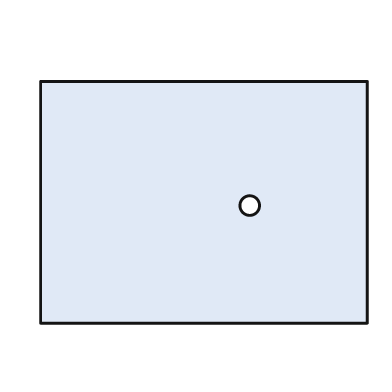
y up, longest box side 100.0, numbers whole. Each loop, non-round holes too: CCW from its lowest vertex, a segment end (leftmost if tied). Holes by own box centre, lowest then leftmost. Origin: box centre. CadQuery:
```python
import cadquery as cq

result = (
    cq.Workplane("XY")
    .moveTo(-50.0, -37.0)
    .lineTo(50.0, -37.0)
    .lineTo(50.0, 37.0)
    .lineTo(-50.0, 37.0)
    .close()
    .moveTo(14.0, -1.0)
    .circle(3.0)
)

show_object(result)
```